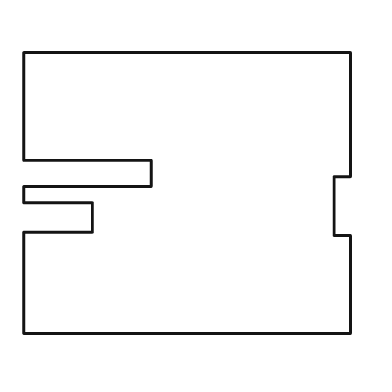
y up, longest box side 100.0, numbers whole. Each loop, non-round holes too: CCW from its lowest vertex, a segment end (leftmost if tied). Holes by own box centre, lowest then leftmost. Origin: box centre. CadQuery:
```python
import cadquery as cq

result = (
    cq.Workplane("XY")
    .moveTo(-50.0, -43.0)
    .lineTo(50.0, -43.0)
    .lineTo(50.0, -13.0)
    .lineTo(45.0, -13.0)
    .lineTo(45.0, 5.0)
    .lineTo(50.0, 5.0)
    .lineTo(50.0, 43.0)
    .lineTo(-50.0, 43.0)
    .lineTo(-50.0, 10.0)
    .lineTo(-11.0, 10.0)
    .lineTo(-11.0, 2.0)
    .lineTo(-50.0, 2.0)
    .lineTo(-50.0, -3.0)
    .lineTo(-29.0, -3.0)
    .lineTo(-29.0, -12.0)
    .lineTo(-50.0, -12.0)
    .close()
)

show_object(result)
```